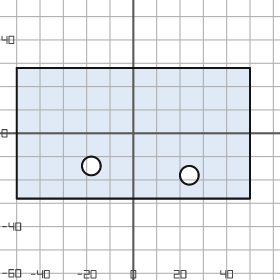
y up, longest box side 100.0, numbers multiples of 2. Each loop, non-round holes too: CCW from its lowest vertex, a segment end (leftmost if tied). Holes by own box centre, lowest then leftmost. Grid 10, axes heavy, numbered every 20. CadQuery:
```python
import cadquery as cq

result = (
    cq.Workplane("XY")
    .moveTo(-50.0, -28.0)
    .lineTo(50.0, -28.0)
    .lineTo(50.0, 28.0)
    .lineTo(-50.0, 28.0)
    .close()
    .moveTo(24.0, -18.0)
    .circle(4.0)
    .moveTo(-18.0, -14.0)
    .circle(4.0)
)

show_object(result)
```